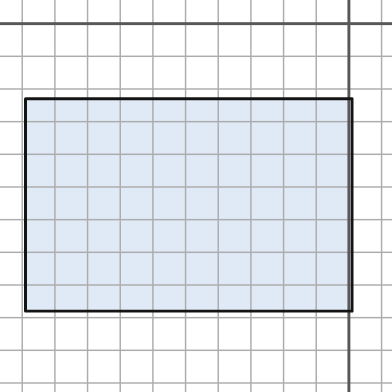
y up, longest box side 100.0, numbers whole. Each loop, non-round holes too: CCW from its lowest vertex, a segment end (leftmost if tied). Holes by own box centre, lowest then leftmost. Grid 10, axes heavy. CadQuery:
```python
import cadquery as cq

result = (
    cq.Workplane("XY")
    .moveTo(-99.0, -88.0)
    .lineTo(1.0, -88.0)
    .lineTo(1.0, -23.0)
    .lineTo(-99.0, -23.0)
    .close()
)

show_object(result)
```